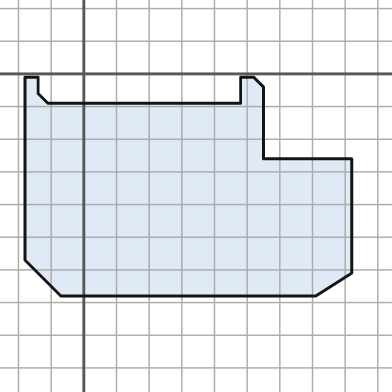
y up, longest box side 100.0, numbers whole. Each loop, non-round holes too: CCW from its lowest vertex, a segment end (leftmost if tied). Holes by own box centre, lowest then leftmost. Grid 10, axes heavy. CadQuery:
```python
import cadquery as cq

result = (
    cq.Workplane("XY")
    .moveTo(-7.0, -68.0)
    .lineTo(71.0, -68.0)
    .lineTo(82.0, -61.0)
    .lineTo(82.0, -26.0)
    .lineTo(55.0, -26.0)
    .lineTo(55.0, -4.0)
    .lineTo(52.0, -1.0)
    .lineTo(48.0, -1.0)
    .lineTo(48.0, -9.0)
    .lineTo(-11.0, -9.0)
    .lineTo(-14.0, -6.0)
    .lineTo(-14.0, -1.0)
    .lineTo(-18.0, -1.0)
    .lineTo(-18.0, -57.0)
    .close()
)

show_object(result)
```